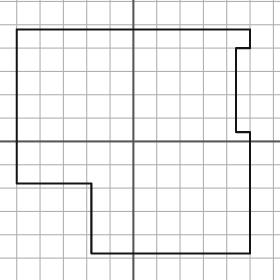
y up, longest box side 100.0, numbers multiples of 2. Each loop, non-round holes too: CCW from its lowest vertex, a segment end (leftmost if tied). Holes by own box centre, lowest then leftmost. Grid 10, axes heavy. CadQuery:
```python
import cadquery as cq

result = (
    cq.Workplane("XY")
    .moveTo(-18.0, -48.0)
    .lineTo(50.0, -48.0)
    .lineTo(50.0, 4.0)
    .lineTo(44.0, 4.0)
    .lineTo(44.0, 40.0)
    .lineTo(50.0, 40.0)
    .lineTo(50.0, 48.0)
    .lineTo(-50.0, 48.0)
    .lineTo(-50.0, -18.0)
    .lineTo(-18.0, -18.0)
    .close()
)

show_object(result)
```